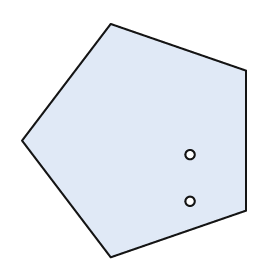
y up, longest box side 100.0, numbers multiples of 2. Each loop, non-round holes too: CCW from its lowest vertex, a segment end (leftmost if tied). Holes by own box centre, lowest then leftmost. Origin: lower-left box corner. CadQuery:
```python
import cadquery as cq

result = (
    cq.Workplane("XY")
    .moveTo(38.0, 0.0)
    .lineTo(96.0, 20.0)
    .lineTo(96.0, 80.0)
    .lineTo(38.0, 100.0)
    .lineTo(0.0, 50.0)
    .close()
    .moveTo(72.0, 24.0)
    .circle(2.0)
    .moveTo(72.0, 44.0)
    .circle(2.0)
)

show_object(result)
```